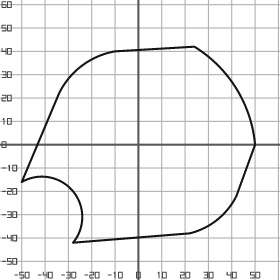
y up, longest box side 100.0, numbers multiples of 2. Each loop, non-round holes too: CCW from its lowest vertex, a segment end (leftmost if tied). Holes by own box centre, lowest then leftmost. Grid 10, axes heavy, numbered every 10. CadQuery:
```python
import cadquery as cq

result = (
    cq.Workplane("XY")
    .moveTo(-28.0, -42.0)
    .lineTo(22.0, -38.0)
    .threePointArc((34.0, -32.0), (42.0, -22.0))
    .lineTo(50.0, 0.0)
    .threePointArc((42.0, 24.0), (24.0, 42.0))
    .lineTo(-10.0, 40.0)
    .threePointArc((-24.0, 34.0), (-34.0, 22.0))
    .lineTo(-50.0, -16.0)
    .threePointArc((-28.0, -20.0), (-28.0, -42.0))
    .close()
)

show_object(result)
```